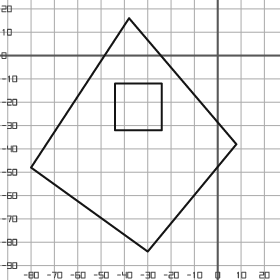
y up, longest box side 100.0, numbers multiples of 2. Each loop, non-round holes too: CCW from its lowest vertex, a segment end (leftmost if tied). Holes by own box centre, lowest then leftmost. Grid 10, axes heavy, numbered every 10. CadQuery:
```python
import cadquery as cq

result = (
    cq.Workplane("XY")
    .moveTo(-30.0, -84.0)
    .lineTo(8.0, -38.0)
    .lineTo(-38.0, 16.0)
    .lineTo(-80.0, -48.0)
    .close()
    .moveTo(-44.0, -32.0)
    .lineTo(-24.0, -32.0)
    .lineTo(-24.0, -12.0)
    .lineTo(-44.0, -12.0)
    .close()
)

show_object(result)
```